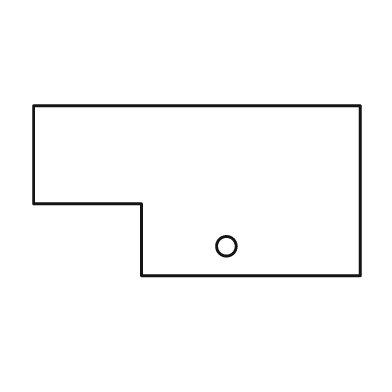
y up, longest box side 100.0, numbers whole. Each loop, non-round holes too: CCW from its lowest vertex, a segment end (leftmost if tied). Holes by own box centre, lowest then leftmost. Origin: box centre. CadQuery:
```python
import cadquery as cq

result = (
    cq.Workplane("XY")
    .moveTo(-17.0, -26.0)
    .lineTo(50.0, -26.0)
    .lineTo(50.0, 26.0)
    .lineTo(-50.0, 26.0)
    .lineTo(-50.0, -4.0)
    .lineTo(-17.0, -4.0)
    .close()
    .moveTo(9.0, -17.0)
    .circle(3.0)
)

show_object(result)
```